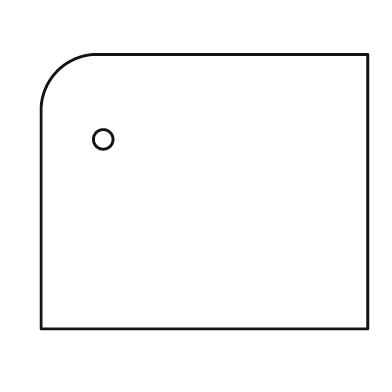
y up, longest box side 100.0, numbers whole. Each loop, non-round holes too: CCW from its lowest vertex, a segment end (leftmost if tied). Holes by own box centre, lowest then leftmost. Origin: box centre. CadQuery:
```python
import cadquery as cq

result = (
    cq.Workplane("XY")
    .moveTo(-50.0, -42.0)
    .lineTo(50.0, -42.0)
    .lineTo(50.0, 42.0)
    .lineTo(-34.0, 42.0)
    .threePointArc((-45.0, 37.0), (-50.0, 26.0))
    .close()
    .moveTo(-31.0, 16.0)
    .circle(3.0)
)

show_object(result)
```